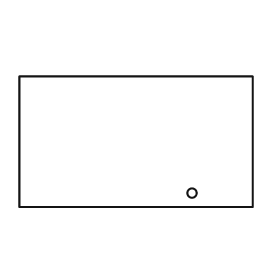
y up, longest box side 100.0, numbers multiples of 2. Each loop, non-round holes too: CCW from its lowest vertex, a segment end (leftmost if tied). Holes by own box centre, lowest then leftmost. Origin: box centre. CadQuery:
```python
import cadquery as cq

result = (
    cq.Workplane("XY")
    .moveTo(-50.0, -28.0)
    .lineTo(50.0, -28.0)
    .lineTo(50.0, 28.0)
    .lineTo(-50.0, 28.0)
    .close()
    .moveTo(24.0, -22.0)
    .circle(2.0)
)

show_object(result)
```